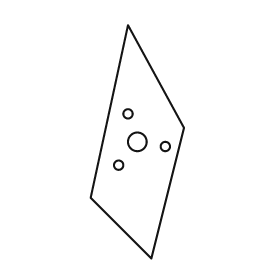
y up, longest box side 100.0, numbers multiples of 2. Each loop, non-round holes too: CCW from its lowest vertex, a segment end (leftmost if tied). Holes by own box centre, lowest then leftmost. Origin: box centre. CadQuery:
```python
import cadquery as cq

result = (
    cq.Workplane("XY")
    .moveTo(6.0, -50.0)
    .lineTo(20.0, 6.0)
    .lineTo(-4.0, 50.0)
    .lineTo(-20.0, -24.0)
    .close()
    .moveTo(-8.0, -10.0)
    .circle(2.0)
    .moveTo(12.0, -2.0)
    .circle(2.0)
    .moveTo(0.0, 0.0)
    .circle(4.0)
    .moveTo(-4.0, 12.0)
    .circle(2.0)
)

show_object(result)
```